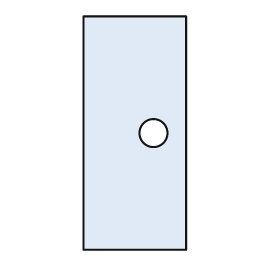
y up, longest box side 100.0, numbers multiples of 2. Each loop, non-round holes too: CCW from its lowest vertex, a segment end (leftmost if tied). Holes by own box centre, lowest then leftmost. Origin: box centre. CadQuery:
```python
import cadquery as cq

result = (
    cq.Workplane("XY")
    .moveTo(-22.0, -50.0)
    .lineTo(22.0, -50.0)
    .lineTo(22.0, 50.0)
    .lineTo(-22.0, 50.0)
    .close()
    .moveTo(8.0, 0.0)
    .circle(6.0)
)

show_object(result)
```